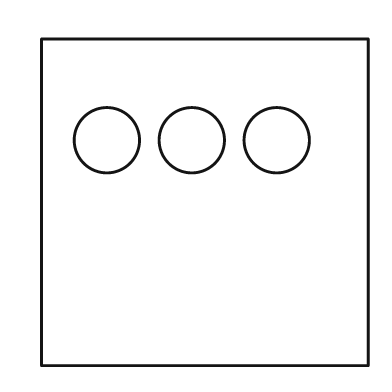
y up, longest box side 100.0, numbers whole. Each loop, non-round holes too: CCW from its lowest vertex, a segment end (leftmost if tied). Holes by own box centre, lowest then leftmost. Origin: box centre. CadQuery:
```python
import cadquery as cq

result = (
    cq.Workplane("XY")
    .moveTo(-50.0, -50.0)
    .lineTo(50.0, -50.0)
    .lineTo(50.0, 50.0)
    .lineTo(-50.0, 50.0)
    .close()
    .moveTo(-30.0, 19.0)
    .circle(10.0)
    .moveTo(-4.0, 19.0)
    .circle(10.0)
    .moveTo(22.0, 19.0)
    .circle(10.0)
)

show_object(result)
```